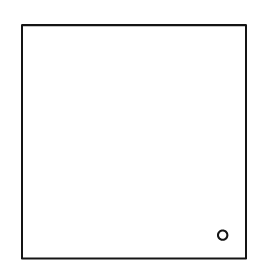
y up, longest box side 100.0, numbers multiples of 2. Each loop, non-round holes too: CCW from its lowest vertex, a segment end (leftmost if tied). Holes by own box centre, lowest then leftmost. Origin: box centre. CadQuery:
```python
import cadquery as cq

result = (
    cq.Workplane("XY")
    .moveTo(-48.0, -50.0)
    .lineTo(48.0, -50.0)
    .lineTo(48.0, 50.0)
    .lineTo(-48.0, 50.0)
    .close()
    .moveTo(38.0, -40.0)
    .circle(2.0)
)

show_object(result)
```